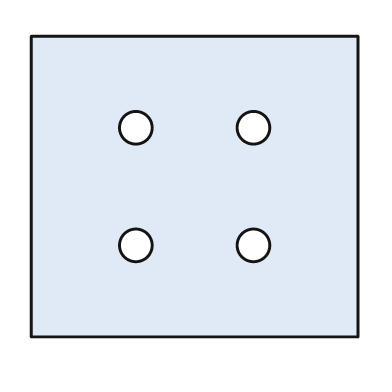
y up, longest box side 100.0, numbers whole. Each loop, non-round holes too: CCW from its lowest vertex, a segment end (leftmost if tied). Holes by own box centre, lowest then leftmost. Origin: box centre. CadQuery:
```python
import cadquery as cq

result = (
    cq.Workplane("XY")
    .moveTo(-50.0, -46.0)
    .lineTo(50.0, -46.0)
    .lineTo(50.0, 46.0)
    .lineTo(-50.0, 46.0)
    .close()
    .moveTo(-18.0, -18.0)
    .circle(5.0)
    .moveTo(18.0, -18.0)
    .circle(5.0)
    .moveTo(-18.0, 18.0)
    .circle(5.0)
    .moveTo(18.0, 18.0)
    .circle(5.0)
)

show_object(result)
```